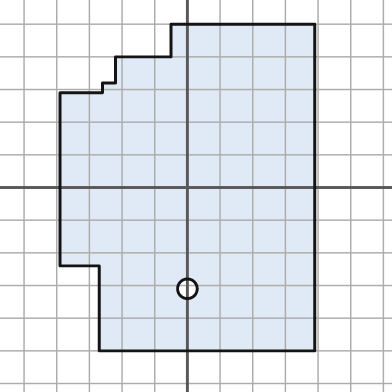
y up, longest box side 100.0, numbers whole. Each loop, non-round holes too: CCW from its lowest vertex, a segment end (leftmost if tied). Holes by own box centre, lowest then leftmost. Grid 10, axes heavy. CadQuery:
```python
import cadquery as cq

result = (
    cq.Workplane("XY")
    .moveTo(-27.0, -50.0)
    .lineTo(39.0, -50.0)
    .lineTo(39.0, 50.0)
    .lineTo(-5.0, 50.0)
    .lineTo(-5.0, 40.0)
    .lineTo(-22.0, 40.0)
    .lineTo(-22.0, 32.0)
    .lineTo(-26.0, 32.0)
    .lineTo(-26.0, 29.0)
    .lineTo(-39.0, 29.0)
    .lineTo(-39.0, -24.0)
    .lineTo(-27.0, -24.0)
    .close()
    .moveTo(0.0, -31.0)
    .circle(3.0)
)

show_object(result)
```